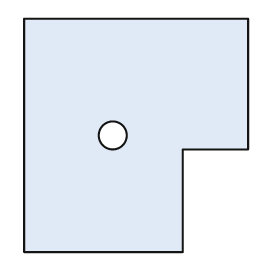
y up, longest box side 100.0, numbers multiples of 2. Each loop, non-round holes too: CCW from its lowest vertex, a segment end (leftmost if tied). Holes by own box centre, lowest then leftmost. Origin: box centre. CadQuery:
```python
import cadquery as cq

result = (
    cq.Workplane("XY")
    .moveTo(-48.0, -50.0)
    .lineTo(20.0, -50.0)
    .lineTo(20.0, -6.0)
    .lineTo(48.0, -6.0)
    .lineTo(48.0, 50.0)
    .lineTo(-48.0, 50.0)
    .close()
    .moveTo(-10.0, 0.0)
    .circle(6.0)
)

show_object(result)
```